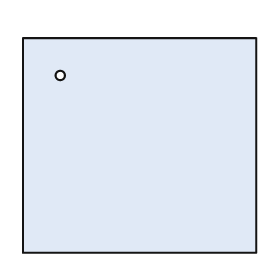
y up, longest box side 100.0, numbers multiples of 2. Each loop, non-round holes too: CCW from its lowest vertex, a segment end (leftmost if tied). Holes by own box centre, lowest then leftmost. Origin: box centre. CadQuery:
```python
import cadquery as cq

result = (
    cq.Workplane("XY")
    .moveTo(-50.0, -46.0)
    .lineTo(50.0, -46.0)
    .lineTo(50.0, 46.0)
    .lineTo(-50.0, 46.0)
    .close()
    .moveTo(-34.0, 30.0)
    .circle(2.0)
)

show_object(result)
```